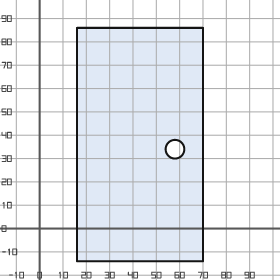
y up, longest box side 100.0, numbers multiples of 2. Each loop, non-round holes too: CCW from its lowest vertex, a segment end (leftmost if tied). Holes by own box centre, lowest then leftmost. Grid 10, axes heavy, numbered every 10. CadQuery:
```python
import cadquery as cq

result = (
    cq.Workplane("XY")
    .moveTo(16.0, -14.0)
    .lineTo(70.0, -14.0)
    .lineTo(70.0, 86.0)
    .lineTo(16.0, 86.0)
    .close()
    .moveTo(58.0, 34.0)
    .circle(4.0)
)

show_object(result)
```